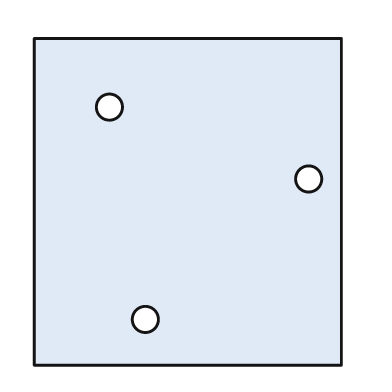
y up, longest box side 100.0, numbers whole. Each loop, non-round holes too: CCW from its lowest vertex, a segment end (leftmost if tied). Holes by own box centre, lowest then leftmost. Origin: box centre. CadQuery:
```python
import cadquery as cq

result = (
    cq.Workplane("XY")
    .moveTo(-47.0, -50.0)
    .lineTo(47.0, -50.0)
    .lineTo(47.0, 50.0)
    .lineTo(-47.0, 50.0)
    .close()
    .moveTo(-13.0, -36.0)
    .circle(4.0)
    .moveTo(37.0, 7.0)
    .circle(4.0)
    .moveTo(-24.0, 29.0)
    .circle(4.0)
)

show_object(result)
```